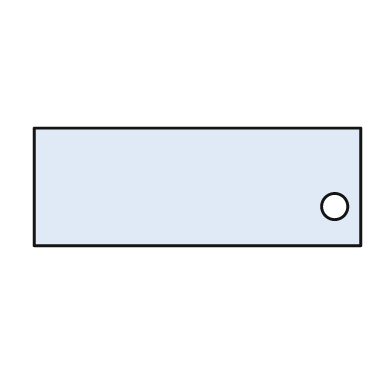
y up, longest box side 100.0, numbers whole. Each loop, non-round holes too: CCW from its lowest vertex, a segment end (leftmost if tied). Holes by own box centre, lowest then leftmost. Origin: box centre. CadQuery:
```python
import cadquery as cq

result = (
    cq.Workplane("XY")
    .moveTo(-50.0, -18.0)
    .lineTo(50.0, -18.0)
    .lineTo(50.0, 18.0)
    .lineTo(-50.0, 18.0)
    .close()
    .moveTo(42.0, -6.0)
    .circle(4.0)
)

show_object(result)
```